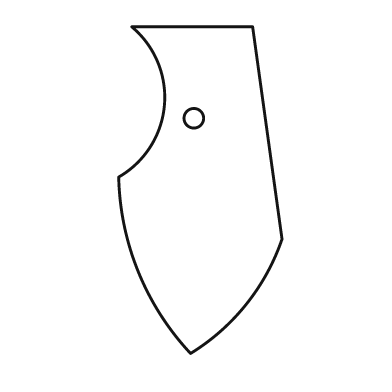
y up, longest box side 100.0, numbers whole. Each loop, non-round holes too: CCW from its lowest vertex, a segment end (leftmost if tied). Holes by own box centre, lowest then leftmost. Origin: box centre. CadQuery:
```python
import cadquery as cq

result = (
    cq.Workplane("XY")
    .moveTo(-3.0, -50.0)
    .threePointArc((14.0, -35.0), (25.0, -15.0))
    .lineTo(16.0, 50.0)
    .lineTo(-21.0, 50.0)
    .threePointArc((-11.0, 26.0), (-25.0, 4.0))
    .threePointArc((-19.0, -25.0), (-3.0, -50.0))
    .close()
    .moveTo(-2.0, 22.0)
    .circle(3.0)
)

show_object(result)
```